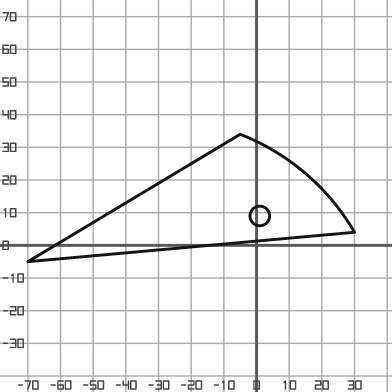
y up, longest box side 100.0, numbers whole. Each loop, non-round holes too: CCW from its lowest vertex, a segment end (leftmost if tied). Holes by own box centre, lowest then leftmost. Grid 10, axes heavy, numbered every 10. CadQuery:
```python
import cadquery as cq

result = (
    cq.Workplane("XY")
    .moveTo(-70.0, -5.0)
    .lineTo(30.0, 4.0)
    .threePointArc((15.0, 22.0), (-5.0, 34.0))
    .close()
    .moveTo(1.0, 9.0)
    .circle(3.0)
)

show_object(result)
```